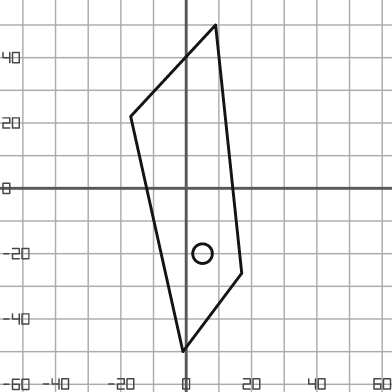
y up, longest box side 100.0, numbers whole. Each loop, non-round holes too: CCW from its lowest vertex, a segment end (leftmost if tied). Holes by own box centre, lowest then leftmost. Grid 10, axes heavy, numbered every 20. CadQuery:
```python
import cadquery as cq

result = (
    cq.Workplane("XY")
    .moveTo(-1.0, -50.0)
    .lineTo(17.0, -26.0)
    .lineTo(9.0, 50.0)
    .lineTo(-17.0, 22.0)
    .close()
    .moveTo(5.0, -20.0)
    .circle(3.0)
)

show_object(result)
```